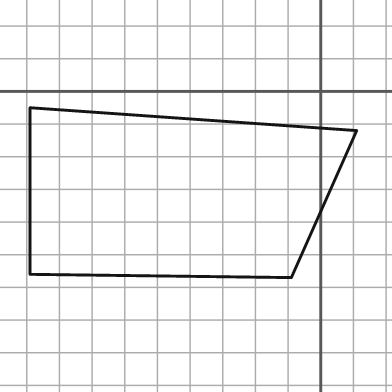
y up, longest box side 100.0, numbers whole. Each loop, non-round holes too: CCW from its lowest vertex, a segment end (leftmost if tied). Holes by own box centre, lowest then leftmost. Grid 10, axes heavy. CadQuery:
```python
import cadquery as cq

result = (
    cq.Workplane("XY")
    .moveTo(-9.0, -57.0)
    .lineTo(11.0, -12.0)
    .lineTo(-89.0, -5.0)
    .lineTo(-89.0, -56.0)
    .close()
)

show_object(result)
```